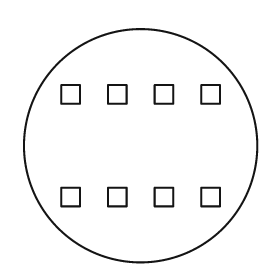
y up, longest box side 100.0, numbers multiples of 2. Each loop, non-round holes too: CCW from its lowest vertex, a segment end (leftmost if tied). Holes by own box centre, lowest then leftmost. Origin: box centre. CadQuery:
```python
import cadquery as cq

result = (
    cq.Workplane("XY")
    .moveTo(0.0, 0.0)
    .circle(50.0)
    .moveTo(-34.0, -26.0)
    .lineTo(-26.0, -26.0)
    .lineTo(-26.0, -18.0)
    .lineTo(-34.0, -18.0)
    .close()
    .moveTo(-14.0, -26.0)
    .lineTo(-6.0, -26.0)
    .lineTo(-6.0, -18.0)
    .lineTo(-14.0, -18.0)
    .close()
    .moveTo(6.0, -26.0)
    .lineTo(14.0, -26.0)
    .lineTo(14.0, -18.0)
    .lineTo(6.0, -18.0)
    .close()
    .moveTo(26.0, -26.0)
    .lineTo(34.0, -26.0)
    .lineTo(34.0, -18.0)
    .lineTo(26.0, -18.0)
    .close()
    .moveTo(-34.0, 18.0)
    .lineTo(-26.0, 18.0)
    .lineTo(-26.0, 26.0)
    .lineTo(-34.0, 26.0)
    .close()
    .moveTo(-14.0, 18.0)
    .lineTo(-6.0, 18.0)
    .lineTo(-6.0, 26.0)
    .lineTo(-14.0, 26.0)
    .close()
    .moveTo(6.0, 18.0)
    .lineTo(14.0, 18.0)
    .lineTo(14.0, 26.0)
    .lineTo(6.0, 26.0)
    .close()
    .moveTo(26.0, 18.0)
    .lineTo(34.0, 18.0)
    .lineTo(34.0, 26.0)
    .lineTo(26.0, 26.0)
    .close()
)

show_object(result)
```